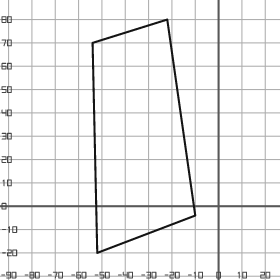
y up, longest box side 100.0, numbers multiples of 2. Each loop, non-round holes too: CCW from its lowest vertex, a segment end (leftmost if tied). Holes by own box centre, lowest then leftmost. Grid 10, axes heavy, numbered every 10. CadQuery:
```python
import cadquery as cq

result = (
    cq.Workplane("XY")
    .moveTo(-52.0, -20.0)
    .lineTo(-10.0, -4.0)
    .lineTo(-22.0, 80.0)
    .lineTo(-54.0, 70.0)
    .close()
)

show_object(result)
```